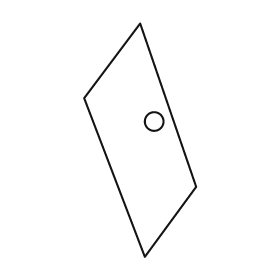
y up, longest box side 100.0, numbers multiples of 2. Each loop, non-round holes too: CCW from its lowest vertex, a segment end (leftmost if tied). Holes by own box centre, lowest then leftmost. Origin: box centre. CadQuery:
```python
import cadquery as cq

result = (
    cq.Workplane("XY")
    .moveTo(2.0, -50.0)
    .lineTo(24.0, -20.0)
    .lineTo(0.0, 50.0)
    .lineTo(-24.0, 18.0)
    .close()
    .moveTo(6.0, 8.0)
    .circle(4.0)
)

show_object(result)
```